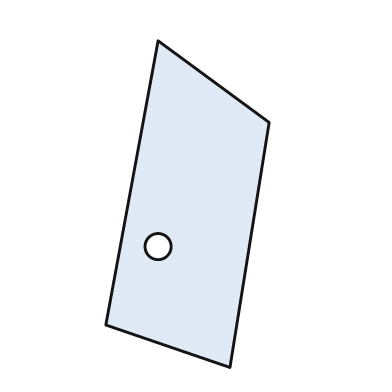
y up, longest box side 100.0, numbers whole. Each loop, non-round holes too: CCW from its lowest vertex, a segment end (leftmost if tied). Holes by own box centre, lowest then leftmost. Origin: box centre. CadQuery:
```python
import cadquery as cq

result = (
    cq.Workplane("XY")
    .moveTo(13.0, -50.0)
    .lineTo(25.0, 25.0)
    .lineTo(-9.0, 50.0)
    .lineTo(-25.0, -37.0)
    .close()
    .moveTo(-9.0, -13.0)
    .circle(4.0)
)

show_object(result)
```